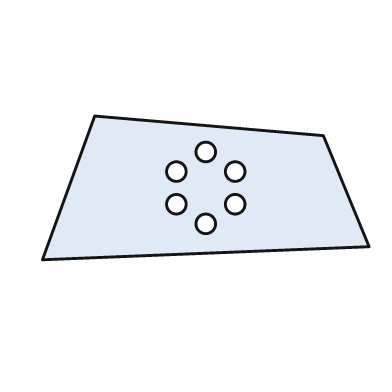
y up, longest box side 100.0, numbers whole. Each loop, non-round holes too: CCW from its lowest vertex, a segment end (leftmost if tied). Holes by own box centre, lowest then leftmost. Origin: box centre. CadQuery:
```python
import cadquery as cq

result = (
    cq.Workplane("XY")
    .moveTo(-50.0, -22.0)
    .lineTo(50.0, -18.0)
    .lineTo(36.0, 16.0)
    .lineTo(-34.0, 22.0)
    .close()
    .moveTo(0.0, -11.0)
    .circle(3.0)
    .moveTo(-9.0, -5.0)
    .circle(3.0)
    .moveTo(9.0, -5.0)
    .circle(3.0)
    .moveTo(-9.0, 5.0)
    .circle(3.0)
    .moveTo(9.0, 5.0)
    .circle(3.0)
    .moveTo(0.0, 11.0)
    .circle(3.0)
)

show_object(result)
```